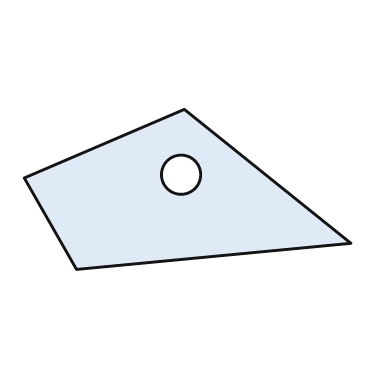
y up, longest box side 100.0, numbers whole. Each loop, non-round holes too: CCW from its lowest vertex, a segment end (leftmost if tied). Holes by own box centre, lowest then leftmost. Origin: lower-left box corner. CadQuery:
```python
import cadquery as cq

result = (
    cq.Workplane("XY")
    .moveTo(16.0, 0.0)
    .lineTo(100.0, 8.0)
    .lineTo(49.0, 49.0)
    .lineTo(0.0, 28.0)
    .close()
    .moveTo(48.0, 29.0)
    .circle(6.0)
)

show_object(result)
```